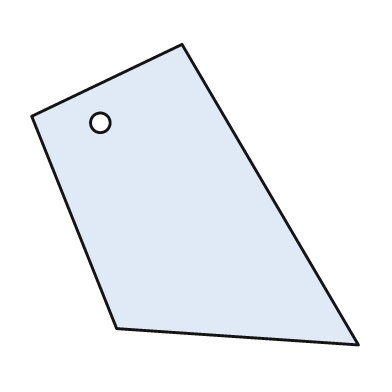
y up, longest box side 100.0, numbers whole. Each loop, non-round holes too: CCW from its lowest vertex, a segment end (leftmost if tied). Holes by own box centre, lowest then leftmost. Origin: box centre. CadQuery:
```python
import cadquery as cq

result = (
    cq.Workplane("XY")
    .moveTo(50.0, -46.0)
    .lineTo(-4.0, 46.0)
    .lineTo(-50.0, 24.0)
    .lineTo(-24.0, -41.0)
    .close()
    .moveTo(-29.0, 22.0)
    .circle(3.0)
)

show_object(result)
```